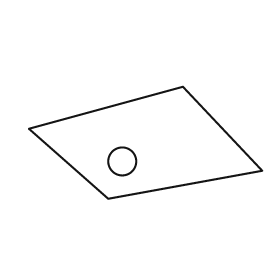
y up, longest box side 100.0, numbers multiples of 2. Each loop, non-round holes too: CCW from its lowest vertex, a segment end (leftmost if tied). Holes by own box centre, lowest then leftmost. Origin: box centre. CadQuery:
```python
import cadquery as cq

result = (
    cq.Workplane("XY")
    .moveTo(-16.0, -24.0)
    .lineTo(50.0, -12.0)
    .lineTo(16.0, 24.0)
    .lineTo(-50.0, 6.0)
    .close()
    .moveTo(-10.0, -8.0)
    .circle(6.0)
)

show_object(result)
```